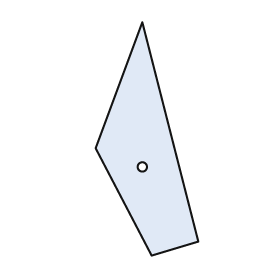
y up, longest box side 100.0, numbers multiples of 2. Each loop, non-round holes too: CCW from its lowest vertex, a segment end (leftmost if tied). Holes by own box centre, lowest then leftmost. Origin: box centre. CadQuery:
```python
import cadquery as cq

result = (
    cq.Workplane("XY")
    .moveTo(2.0, -50.0)
    .lineTo(22.0, -44.0)
    .lineTo(-2.0, 50.0)
    .lineTo(-22.0, -4.0)
    .close()
    .moveTo(-2.0, -12.0)
    .circle(2.0)
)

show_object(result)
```